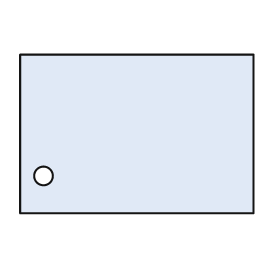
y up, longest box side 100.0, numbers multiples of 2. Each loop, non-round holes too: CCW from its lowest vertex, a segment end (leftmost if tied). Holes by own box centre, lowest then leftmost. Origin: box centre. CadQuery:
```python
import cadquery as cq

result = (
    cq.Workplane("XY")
    .moveTo(-50.0, -34.0)
    .lineTo(50.0, -34.0)
    .lineTo(50.0, 34.0)
    .lineTo(-50.0, 34.0)
    .close()
    .moveTo(-40.0, -18.0)
    .circle(4.0)
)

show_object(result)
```